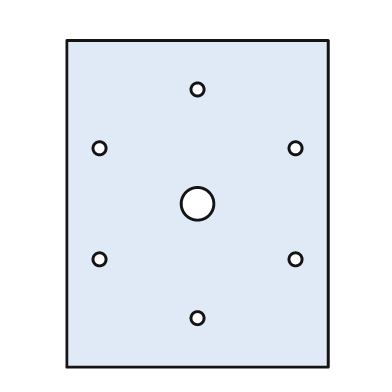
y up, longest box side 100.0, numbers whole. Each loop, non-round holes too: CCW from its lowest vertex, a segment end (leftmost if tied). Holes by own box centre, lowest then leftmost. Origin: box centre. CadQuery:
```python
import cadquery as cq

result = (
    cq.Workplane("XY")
    .moveTo(-40.0, -50.0)
    .lineTo(40.0, -50.0)
    .lineTo(40.0, 50.0)
    .lineTo(-40.0, 50.0)
    .close()
    .moveTo(0.0, -35.0)
    .circle(2.0)
    .moveTo(-30.0, -17.0)
    .circle(2.0)
    .moveTo(30.0, -17.0)
    .circle(2.0)
    .moveTo(0.0, 0.0)
    .circle(5.0)
    .moveTo(-30.0, 17.0)
    .circle(2.0)
    .moveTo(30.0, 17.0)
    .circle(2.0)
    .moveTo(0.0, 35.0)
    .circle(2.0)
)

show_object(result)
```